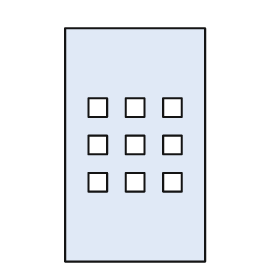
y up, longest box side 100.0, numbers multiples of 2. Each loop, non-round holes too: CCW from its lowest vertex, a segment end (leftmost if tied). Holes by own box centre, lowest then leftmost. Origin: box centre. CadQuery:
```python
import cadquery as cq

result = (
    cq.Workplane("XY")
    .moveTo(-30.0, -50.0)
    .lineTo(30.0, -50.0)
    .lineTo(30.0, 50.0)
    .lineTo(-30.0, 50.0)
    .close()
    .moveTo(-20.0, -20.0)
    .lineTo(-12.0, -20.0)
    .lineTo(-12.0, -12.0)
    .lineTo(-20.0, -12.0)
    .close()
    .moveTo(-4.0, -20.0)
    .lineTo(4.0, -20.0)
    .lineTo(4.0, -12.0)
    .lineTo(-4.0, -12.0)
    .close()
    .moveTo(12.0, -20.0)
    .lineTo(20.0, -20.0)
    .lineTo(20.0, -12.0)
    .lineTo(12.0, -12.0)
    .close()
    .moveTo(-20.0, -4.0)
    .lineTo(-12.0, -4.0)
    .lineTo(-12.0, 4.0)
    .lineTo(-20.0, 4.0)
    .close()
    .moveTo(-4.0, -4.0)
    .lineTo(4.0, -4.0)
    .lineTo(4.0, 4.0)
    .lineTo(-4.0, 4.0)
    .close()
    .moveTo(12.0, -4.0)
    .lineTo(20.0, -4.0)
    .lineTo(20.0, 4.0)
    .lineTo(12.0, 4.0)
    .close()
    .moveTo(-20.0, 12.0)
    .lineTo(-12.0, 12.0)
    .lineTo(-12.0, 20.0)
    .lineTo(-20.0, 20.0)
    .close()
    .moveTo(-4.0, 12.0)
    .lineTo(4.0, 12.0)
    .lineTo(4.0, 20.0)
    .lineTo(-4.0, 20.0)
    .close()
    .moveTo(12.0, 12.0)
    .lineTo(20.0, 12.0)
    .lineTo(20.0, 20.0)
    .lineTo(12.0, 20.0)
    .close()
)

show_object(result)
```